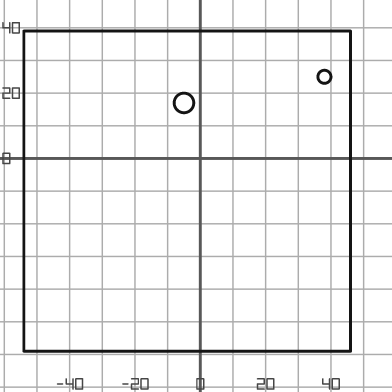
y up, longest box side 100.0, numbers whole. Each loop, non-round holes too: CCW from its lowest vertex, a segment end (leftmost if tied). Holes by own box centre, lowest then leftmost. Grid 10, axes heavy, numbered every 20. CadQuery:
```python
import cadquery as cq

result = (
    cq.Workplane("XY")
    .moveTo(-54.0, -59.0)
    .lineTo(46.0, -59.0)
    .lineTo(46.0, 39.0)
    .lineTo(-54.0, 39.0)
    .close()
    .moveTo(-5.0, 17.0)
    .circle(3.0)
    .moveTo(38.0, 25.0)
    .circle(2.0)
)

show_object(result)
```